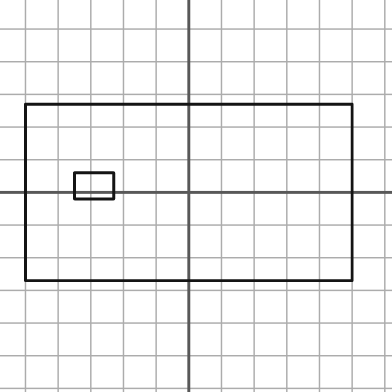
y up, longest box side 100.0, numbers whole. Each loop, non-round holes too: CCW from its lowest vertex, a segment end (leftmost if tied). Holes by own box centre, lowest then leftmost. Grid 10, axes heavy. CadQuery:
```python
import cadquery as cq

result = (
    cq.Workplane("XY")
    .moveTo(-50.0, -27.0)
    .lineTo(50.0, -27.0)
    .lineTo(50.0, 27.0)
    .lineTo(-50.0, 27.0)
    .close()
    .moveTo(-35.0, -2.0)
    .lineTo(-23.0, -2.0)
    .lineTo(-23.0, 6.0)
    .lineTo(-35.0, 6.0)
    .close()
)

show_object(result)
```